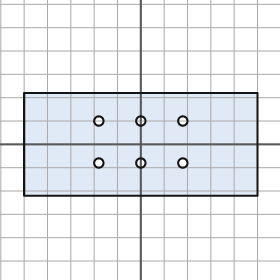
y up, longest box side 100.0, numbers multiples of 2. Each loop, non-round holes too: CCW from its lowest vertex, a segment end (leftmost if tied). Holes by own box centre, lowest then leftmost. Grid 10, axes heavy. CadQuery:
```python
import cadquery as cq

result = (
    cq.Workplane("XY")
    .moveTo(-50.0, -22.0)
    .lineTo(50.0, -22.0)
    .lineTo(50.0, 22.0)
    .lineTo(-50.0, 22.0)
    .close()
    .moveTo(-18.0, -8.0)
    .circle(2.0)
    .moveTo(0.0, -8.0)
    .circle(2.0)
    .moveTo(18.0, -8.0)
    .circle(2.0)
    .moveTo(-18.0, 10.0)
    .circle(2.0)
    .moveTo(0.0, 10.0)
    .circle(2.0)
    .moveTo(18.0, 10.0)
    .circle(2.0)
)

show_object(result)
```